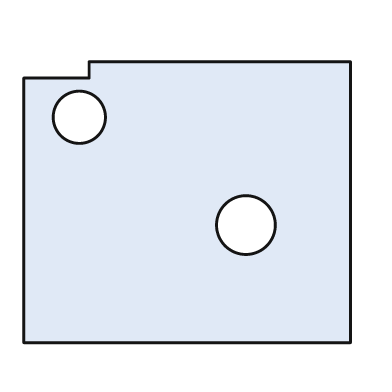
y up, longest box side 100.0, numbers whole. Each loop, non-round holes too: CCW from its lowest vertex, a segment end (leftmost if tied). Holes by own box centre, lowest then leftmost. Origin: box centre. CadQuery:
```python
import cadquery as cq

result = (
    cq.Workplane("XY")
    .moveTo(-50.0, -43.0)
    .lineTo(50.0, -43.0)
    .lineTo(50.0, 43.0)
    .lineTo(-30.0, 43.0)
    .lineTo(-30.0, 38.0)
    .lineTo(-50.0, 38.0)
    .close()
    .moveTo(18.0, -7.0)
    .circle(9.0)
    .moveTo(-33.0, 26.0)
    .circle(8.0)
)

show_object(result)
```